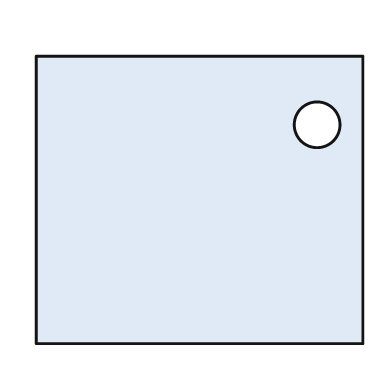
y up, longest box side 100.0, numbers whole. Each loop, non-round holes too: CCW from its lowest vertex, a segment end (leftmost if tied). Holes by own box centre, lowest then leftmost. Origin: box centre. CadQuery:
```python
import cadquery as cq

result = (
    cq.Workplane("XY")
    .moveTo(-50.0, -44.0)
    .lineTo(50.0, -44.0)
    .lineTo(50.0, 44.0)
    .lineTo(-50.0, 44.0)
    .close()
    .moveTo(36.0, 23.0)
    .circle(7.0)
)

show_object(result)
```